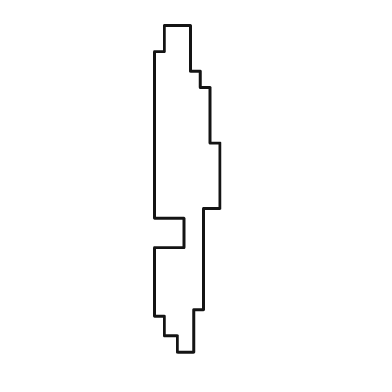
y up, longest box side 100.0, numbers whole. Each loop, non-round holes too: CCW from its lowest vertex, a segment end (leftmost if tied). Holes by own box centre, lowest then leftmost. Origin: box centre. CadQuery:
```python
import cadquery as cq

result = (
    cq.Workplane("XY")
    .moveTo(-3.0, -50.0)
    .lineTo(2.0, -50.0)
    .lineTo(2.0, -37.0)
    .lineTo(5.0, -37.0)
    .lineTo(5.0, -6.0)
    .lineTo(10.0, -6.0)
    .lineTo(10.0, 14.0)
    .lineTo(7.0, 14.0)
    .lineTo(7.0, 31.0)
    .lineTo(4.0, 31.0)
    .lineTo(4.0, 36.0)
    .lineTo(1.0, 36.0)
    .lineTo(1.0, 50.0)
    .lineTo(-7.0, 50.0)
    .lineTo(-7.0, 42.0)
    .lineTo(-10.0, 42.0)
    .lineTo(-10.0, -9.0)
    .lineTo(-1.0, -9.0)
    .lineTo(-1.0, -18.0)
    .lineTo(-10.0, -18.0)
    .lineTo(-10.0, -39.0)
    .lineTo(-7.0, -39.0)
    .lineTo(-7.0, -45.0)
    .lineTo(-3.0, -45.0)
    .close()
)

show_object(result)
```